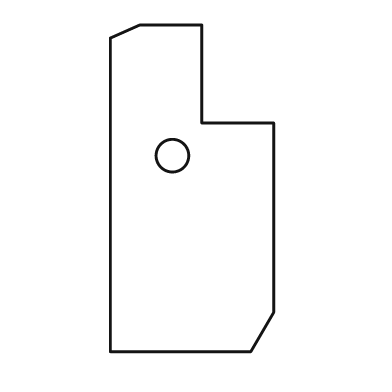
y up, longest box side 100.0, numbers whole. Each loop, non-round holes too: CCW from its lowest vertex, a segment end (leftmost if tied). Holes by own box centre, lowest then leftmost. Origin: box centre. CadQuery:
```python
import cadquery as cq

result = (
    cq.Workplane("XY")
    .moveTo(-25.0, -50.0)
    .lineTo(18.0, -50.0)
    .lineTo(25.0, -38.0)
    .lineTo(25.0, 20.0)
    .lineTo(3.0, 20.0)
    .lineTo(3.0, 50.0)
    .lineTo(-16.0, 50.0)
    .lineTo(-25.0, 46.0)
    .close()
    .moveTo(-6.0, 10.0)
    .circle(5.0)
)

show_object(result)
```